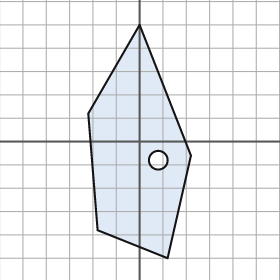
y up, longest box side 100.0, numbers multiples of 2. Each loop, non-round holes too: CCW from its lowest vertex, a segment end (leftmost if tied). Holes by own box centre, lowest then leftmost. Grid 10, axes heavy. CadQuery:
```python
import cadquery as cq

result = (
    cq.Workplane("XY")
    .moveTo(12.0, -50.0)
    .lineTo(22.0, -6.0)
    .lineTo(0.0, 50.0)
    .lineTo(-22.0, 12.0)
    .lineTo(-18.0, -38.0)
    .close()
    .moveTo(8.0, -8.0)
    .circle(4.0)
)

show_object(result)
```